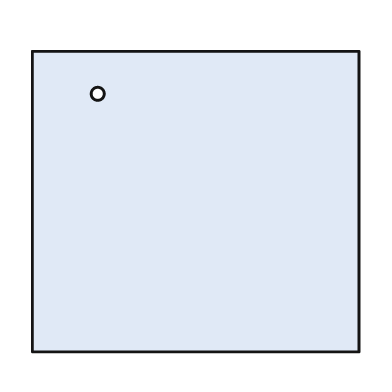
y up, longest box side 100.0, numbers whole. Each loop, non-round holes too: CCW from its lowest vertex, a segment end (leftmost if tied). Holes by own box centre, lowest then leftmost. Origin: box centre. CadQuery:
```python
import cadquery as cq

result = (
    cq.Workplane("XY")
    .moveTo(-50.0, -46.0)
    .lineTo(50.0, -46.0)
    .lineTo(50.0, 46.0)
    .lineTo(-50.0, 46.0)
    .close()
    .moveTo(-30.0, 33.0)
    .circle(2.0)
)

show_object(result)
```